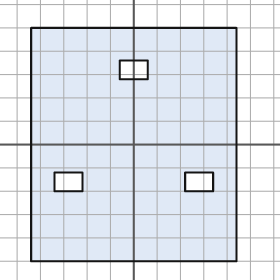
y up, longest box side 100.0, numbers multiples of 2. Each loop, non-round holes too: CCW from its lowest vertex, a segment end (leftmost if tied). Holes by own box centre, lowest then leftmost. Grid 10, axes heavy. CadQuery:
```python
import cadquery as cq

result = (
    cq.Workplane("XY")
    .moveTo(-44.0, -50.0)
    .lineTo(44.0, -50.0)
    .lineTo(44.0, 50.0)
    .lineTo(-44.0, 50.0)
    .close()
    .moveTo(-34.0, -20.0)
    .lineTo(-22.0, -20.0)
    .lineTo(-22.0, -12.0)
    .lineTo(-34.0, -12.0)
    .close()
    .moveTo(22.0, -20.0)
    .lineTo(34.0, -20.0)
    .lineTo(34.0, -12.0)
    .lineTo(22.0, -12.0)
    .close()
    .moveTo(-6.0, 28.0)
    .lineTo(6.0, 28.0)
    .lineTo(6.0, 36.0)
    .lineTo(-6.0, 36.0)
    .close()
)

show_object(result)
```